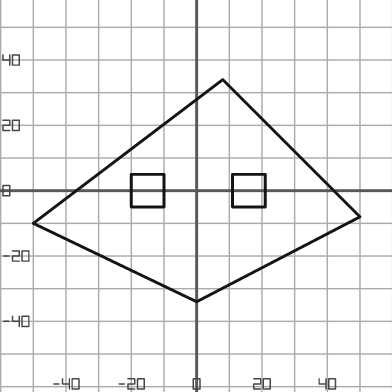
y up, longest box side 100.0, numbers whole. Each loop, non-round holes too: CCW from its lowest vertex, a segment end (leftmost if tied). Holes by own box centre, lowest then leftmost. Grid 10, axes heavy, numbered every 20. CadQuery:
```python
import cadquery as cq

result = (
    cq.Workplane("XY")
    .moveTo(0.0, -34.0)
    .lineTo(50.0, -8.0)
    .lineTo(8.0, 34.0)
    .lineTo(-50.0, -10.0)
    .close()
    .moveTo(-20.0, -5.0)
    .lineTo(-10.0, -5.0)
    .lineTo(-10.0, 5.0)
    .lineTo(-20.0, 5.0)
    .close()
    .moveTo(11.0, -5.0)
    .lineTo(21.0, -5.0)
    .lineTo(21.0, 5.0)
    .lineTo(11.0, 5.0)
    .close()
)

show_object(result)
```